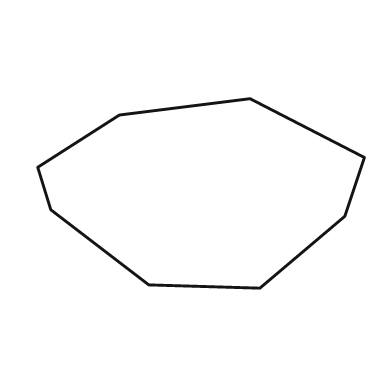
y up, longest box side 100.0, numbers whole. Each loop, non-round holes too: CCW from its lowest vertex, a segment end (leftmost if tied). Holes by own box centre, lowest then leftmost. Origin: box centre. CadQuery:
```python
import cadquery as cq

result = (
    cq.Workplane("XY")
    .moveTo(18.0, -29.0)
    .lineTo(44.0, -7.0)
    .lineTo(50.0, 11.0)
    .lineTo(15.0, 29.0)
    .lineTo(-25.0, 24.0)
    .lineTo(-50.0, 8.0)
    .lineTo(-46.0, -5.0)
    .lineTo(-16.0, -28.0)
    .close()
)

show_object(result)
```